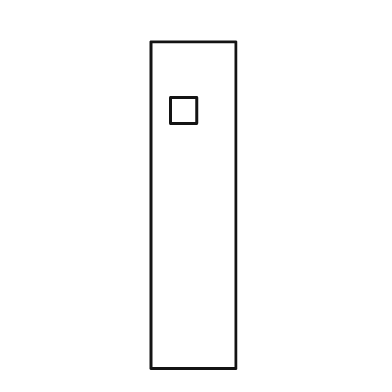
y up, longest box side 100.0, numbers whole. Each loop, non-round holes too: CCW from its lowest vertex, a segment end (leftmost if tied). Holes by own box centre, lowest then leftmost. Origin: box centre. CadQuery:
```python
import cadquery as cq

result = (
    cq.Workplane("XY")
    .moveTo(-13.0, -50.0)
    .lineTo(13.0, -50.0)
    .lineTo(13.0, 50.0)
    .lineTo(-13.0, 50.0)
    .close()
    .moveTo(-7.0, 25.0)
    .lineTo(1.0, 25.0)
    .lineTo(1.0, 33.0)
    .lineTo(-7.0, 33.0)
    .close()
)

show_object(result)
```